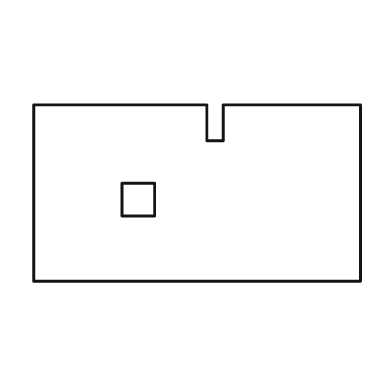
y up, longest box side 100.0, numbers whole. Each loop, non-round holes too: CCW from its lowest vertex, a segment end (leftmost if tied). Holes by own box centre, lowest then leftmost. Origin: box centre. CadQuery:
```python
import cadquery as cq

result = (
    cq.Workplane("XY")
    .moveTo(-50.0, -27.0)
    .lineTo(50.0, -27.0)
    .lineTo(50.0, 27.0)
    .lineTo(8.0, 27.0)
    .lineTo(8.0, 16.0)
    .lineTo(3.0, 16.0)
    .lineTo(3.0, 27.0)
    .lineTo(-50.0, 27.0)
    .close()
    .moveTo(-23.0, -7.0)
    .lineTo(-13.0, -7.0)
    .lineTo(-13.0, 3.0)
    .lineTo(-23.0, 3.0)
    .close()
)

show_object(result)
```